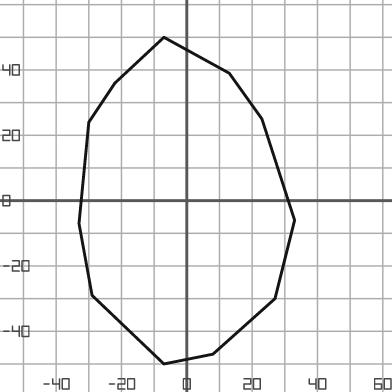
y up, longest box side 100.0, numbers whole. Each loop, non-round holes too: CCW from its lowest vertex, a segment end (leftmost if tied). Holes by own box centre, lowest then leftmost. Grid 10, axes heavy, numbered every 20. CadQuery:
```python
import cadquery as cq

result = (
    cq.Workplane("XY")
    .moveTo(-7.0, -50.0)
    .lineTo(8.0, -47.0)
    .lineTo(27.0, -30.0)
    .lineTo(33.0, -6.0)
    .lineTo(23.0, 25.0)
    .lineTo(13.0, 39.0)
    .lineTo(-7.0, 50.0)
    .lineTo(-22.0, 36.0)
    .lineTo(-30.0, 24.0)
    .lineTo(-33.0, -7.0)
    .lineTo(-29.0, -29.0)
    .close()
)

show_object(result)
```